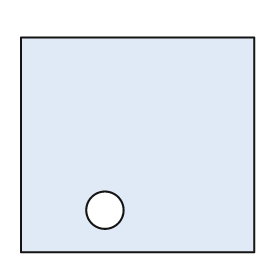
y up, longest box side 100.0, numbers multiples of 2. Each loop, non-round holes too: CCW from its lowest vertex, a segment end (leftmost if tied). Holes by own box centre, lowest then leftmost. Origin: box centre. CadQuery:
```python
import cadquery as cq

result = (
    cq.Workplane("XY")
    .moveTo(-50.0, -46.0)
    .lineTo(50.0, -46.0)
    .lineTo(50.0, 46.0)
    .lineTo(-50.0, 46.0)
    .close()
    .moveTo(-14.0, -28.0)
    .circle(8.0)
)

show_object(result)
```